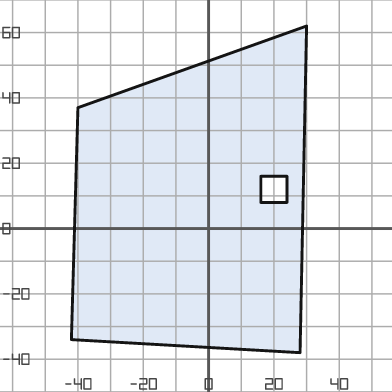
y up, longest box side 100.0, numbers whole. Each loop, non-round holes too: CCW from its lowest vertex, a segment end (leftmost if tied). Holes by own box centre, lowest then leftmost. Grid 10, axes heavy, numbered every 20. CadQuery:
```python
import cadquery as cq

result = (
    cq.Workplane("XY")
    .moveTo(28.0, -38.0)
    .lineTo(30.0, 62.0)
    .lineTo(-40.0, 37.0)
    .lineTo(-42.0, -34.0)
    .close()
    .moveTo(16.0, 8.0)
    .lineTo(24.0, 8.0)
    .lineTo(24.0, 16.0)
    .lineTo(16.0, 16.0)
    .close()
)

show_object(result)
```